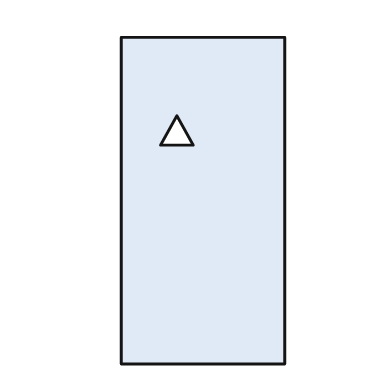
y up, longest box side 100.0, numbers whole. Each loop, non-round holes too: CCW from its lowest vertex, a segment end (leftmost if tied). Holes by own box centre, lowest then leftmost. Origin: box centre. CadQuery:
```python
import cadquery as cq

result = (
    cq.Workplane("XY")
    .moveTo(-25.0, -50.0)
    .lineTo(25.0, -50.0)
    .lineTo(25.0, 50.0)
    .lineTo(-25.0, 50.0)
    .close()
    .moveTo(-13.0, 17.0)
    .lineTo(-3.0, 17.0)
    .lineTo(-8.0, 26.0)
    .close()
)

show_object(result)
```